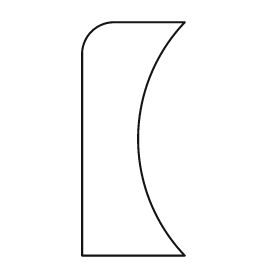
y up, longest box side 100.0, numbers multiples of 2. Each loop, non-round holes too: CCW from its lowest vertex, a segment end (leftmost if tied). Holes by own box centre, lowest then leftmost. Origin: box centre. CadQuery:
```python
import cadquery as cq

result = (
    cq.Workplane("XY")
    .moveTo(-22.0, -50.0)
    .lineTo(22.0, -50.0)
    .threePointArc((2.0, 0.0), (22.0, 50.0))
    .lineTo(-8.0, 50.0)
    .threePointArc((-18.0, 46.0), (-22.0, 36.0))
    .close()
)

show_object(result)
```